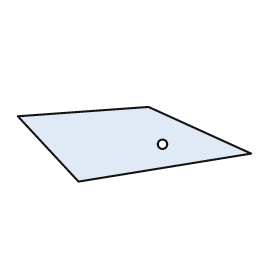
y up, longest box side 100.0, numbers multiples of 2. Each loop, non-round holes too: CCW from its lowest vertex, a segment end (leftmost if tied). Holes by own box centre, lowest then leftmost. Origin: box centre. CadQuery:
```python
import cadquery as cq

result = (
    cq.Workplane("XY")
    .moveTo(-24.0, -16.0)
    .lineTo(50.0, -4.0)
    .lineTo(6.0, 16.0)
    .lineTo(-50.0, 12.0)
    .close()
    .moveTo(12.0, 0.0)
    .circle(2.0)
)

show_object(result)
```